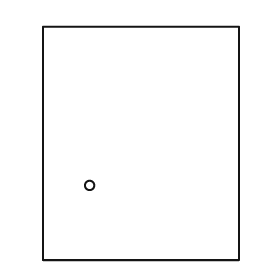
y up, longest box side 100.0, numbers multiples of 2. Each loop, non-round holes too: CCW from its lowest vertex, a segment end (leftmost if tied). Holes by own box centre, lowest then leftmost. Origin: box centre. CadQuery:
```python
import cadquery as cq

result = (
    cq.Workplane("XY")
    .moveTo(-42.0, -50.0)
    .lineTo(42.0, -50.0)
    .lineTo(42.0, 50.0)
    .lineTo(-42.0, 50.0)
    .close()
    .moveTo(-22.0, -18.0)
    .circle(2.0)
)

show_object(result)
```